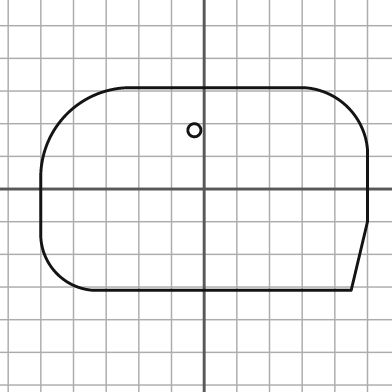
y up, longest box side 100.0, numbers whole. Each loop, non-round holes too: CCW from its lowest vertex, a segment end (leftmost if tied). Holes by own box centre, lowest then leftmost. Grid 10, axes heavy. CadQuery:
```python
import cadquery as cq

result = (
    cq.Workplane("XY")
    .moveTo(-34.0, -31.0)
    .lineTo(45.0, -31.0)
    .lineTo(50.0, -10.0)
    .lineTo(50.0, 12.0)
    .threePointArc((44.0, 25.0), (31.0, 31.0))
    .lineTo(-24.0, 31.0)
    .threePointArc((-42.0, 23.0), (-50.0, 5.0))
    .lineTo(-50.0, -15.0)
    .threePointArc((-45.0, -26.0), (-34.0, -31.0))
    .close()
    .moveTo(-3.0, 18.0)
    .circle(2.0)
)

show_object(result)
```